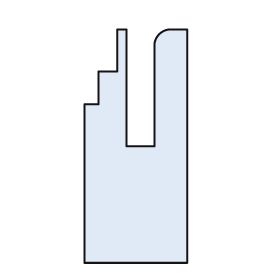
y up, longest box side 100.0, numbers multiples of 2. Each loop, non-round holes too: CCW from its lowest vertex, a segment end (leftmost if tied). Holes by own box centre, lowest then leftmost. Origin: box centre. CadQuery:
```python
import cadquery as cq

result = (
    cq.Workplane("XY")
    .moveTo(-22.0, -50.0)
    .lineTo(22.0, -50.0)
    .lineTo(22.0, 50.0)
    .lineTo(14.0, 50.0)
    .threePointArc((10.0, 48.0), (8.0, 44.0))
    .lineTo(8.0, 0.0)
    .lineTo(-4.0, 0.0)
    .lineTo(-4.0, 50.0)
    .lineTo(-8.0, 50.0)
    .lineTo(-8.0, 32.0)
    .lineTo(-16.0, 32.0)
    .lineTo(-16.0, 18.0)
    .lineTo(-22.0, 18.0)
    .close()
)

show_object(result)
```